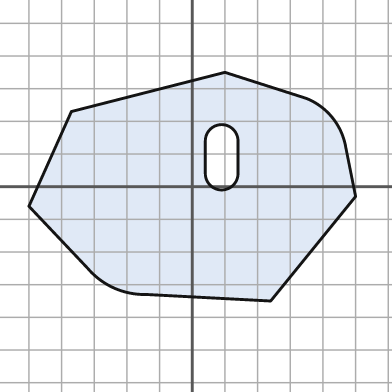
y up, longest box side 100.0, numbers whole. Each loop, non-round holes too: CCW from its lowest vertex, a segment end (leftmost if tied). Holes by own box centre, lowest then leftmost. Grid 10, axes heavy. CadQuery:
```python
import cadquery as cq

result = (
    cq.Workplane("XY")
    .moveTo(24.0, -35.0)
    .lineTo(50.0, -3.0)
    .lineTo(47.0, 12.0)
    .threePointArc((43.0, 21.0), (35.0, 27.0))
    .lineTo(10.0, 35.0)
    .lineTo(-37.0, 23.0)
    .lineTo(-50.0, -6.0)
    .lineTo(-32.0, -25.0)
    .threePointArc((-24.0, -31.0), (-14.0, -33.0))
    .close()
    .moveTo(4.0, 4.0)
    .threePointArc((9.0, -1.0), (14.0, 4.0))
    .lineTo(14.0, 14.0)
    .threePointArc((9.0, 19.0), (4.0, 14.0))
    .close()
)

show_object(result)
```